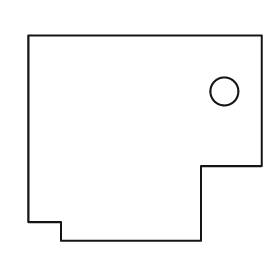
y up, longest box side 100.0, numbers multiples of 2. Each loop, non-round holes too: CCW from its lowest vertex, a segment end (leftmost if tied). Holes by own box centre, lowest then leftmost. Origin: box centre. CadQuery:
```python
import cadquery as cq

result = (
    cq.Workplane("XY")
    .moveTo(-36.0, -44.0)
    .lineTo(24.0, -44.0)
    .lineTo(24.0, -12.0)
    .lineTo(50.0, -12.0)
    .lineTo(50.0, 44.0)
    .lineTo(-50.0, 44.0)
    .lineTo(-50.0, -36.0)
    .lineTo(-36.0, -36.0)
    .close()
    .moveTo(34.0, 20.0)
    .circle(6.0)
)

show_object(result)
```